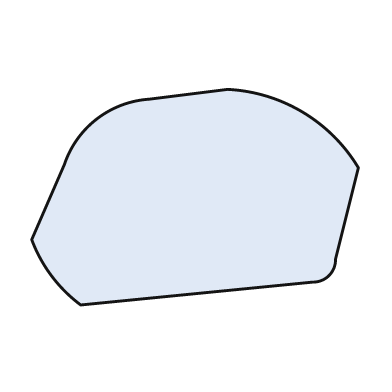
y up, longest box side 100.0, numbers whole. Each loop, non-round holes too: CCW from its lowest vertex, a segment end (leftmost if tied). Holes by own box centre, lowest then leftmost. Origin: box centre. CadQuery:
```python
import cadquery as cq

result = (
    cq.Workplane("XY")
    .moveTo(-35.0, -33.0)
    .lineTo(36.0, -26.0)
    .threePointArc((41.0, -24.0), (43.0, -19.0))
    .lineTo(50.0, 9.0)
    .threePointArc((33.0, 26.0), (10.0, 33.0))
    .lineTo(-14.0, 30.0)
    .threePointArc((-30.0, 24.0), (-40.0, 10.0))
    .lineTo(-50.0, -13.0)
    .threePointArc((-44.0, -24.0), (-35.0, -33.0))
    .close()
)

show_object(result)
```